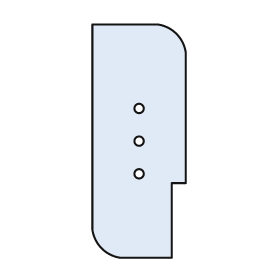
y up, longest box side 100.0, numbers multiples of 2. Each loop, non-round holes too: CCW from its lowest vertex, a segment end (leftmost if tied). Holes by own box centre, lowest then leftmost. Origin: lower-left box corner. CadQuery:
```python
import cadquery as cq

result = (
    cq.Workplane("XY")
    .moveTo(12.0, 0.0)
    .lineTo(34.0, 0.0)
    .lineTo(34.0, 32.0)
    .lineTo(40.0, 32.0)
    .lineTo(40.0, 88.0)
    .threePointArc((36.0, 96.0), (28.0, 100.0))
    .lineTo(0.0, 100.0)
    .lineTo(0.0, 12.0)
    .threePointArc((4.0, 4.0), (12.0, 0.0))
    .close()
    .moveTo(20.0, 36.0)
    .circle(2.0)
    .moveTo(20.0, 50.0)
    .circle(2.0)
    .moveTo(20.0, 64.0)
    .circle(2.0)
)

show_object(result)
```